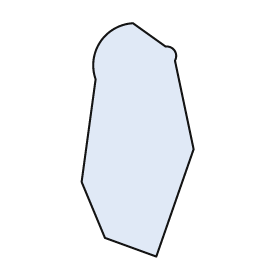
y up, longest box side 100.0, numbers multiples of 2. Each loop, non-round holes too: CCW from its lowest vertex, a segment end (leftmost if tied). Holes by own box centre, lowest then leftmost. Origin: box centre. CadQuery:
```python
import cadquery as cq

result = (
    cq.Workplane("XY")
    .moveTo(8.0, -50.0)
    .lineTo(24.0, -4.0)
    .lineTo(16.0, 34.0)
    .threePointArc((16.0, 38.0), (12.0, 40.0))
    .lineTo(-2.0, 50.0)
    .threePointArc((-16.0, 42.0), (-18.0, 26.0))
    .lineTo(-24.0, -18.0)
    .lineTo(-14.0, -42.0)
    .close()
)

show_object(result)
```